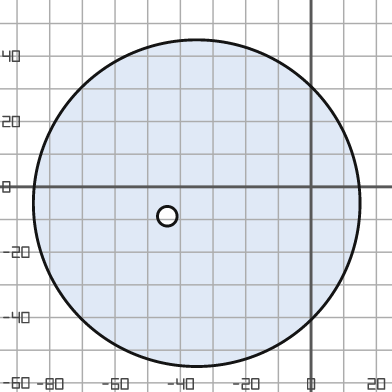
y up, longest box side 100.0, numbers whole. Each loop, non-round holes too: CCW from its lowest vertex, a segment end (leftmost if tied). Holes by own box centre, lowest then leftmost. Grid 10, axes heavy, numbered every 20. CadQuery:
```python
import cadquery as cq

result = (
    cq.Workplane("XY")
    .moveTo(-35.0, -5.0)
    .circle(50.0)
    .moveTo(-44.0, -9.0)
    .circle(3.0)
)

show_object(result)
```